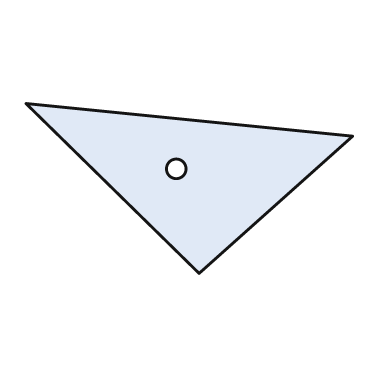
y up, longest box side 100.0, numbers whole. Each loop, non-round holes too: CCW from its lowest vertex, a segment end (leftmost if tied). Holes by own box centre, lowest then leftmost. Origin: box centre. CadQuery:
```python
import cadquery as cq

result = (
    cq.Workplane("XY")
    .moveTo(3.0, -26.0)
    .lineTo(50.0, 16.0)
    .lineTo(-50.0, 26.0)
    .close()
    .moveTo(-4.0, 6.0)
    .circle(3.0)
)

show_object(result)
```